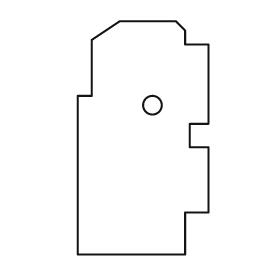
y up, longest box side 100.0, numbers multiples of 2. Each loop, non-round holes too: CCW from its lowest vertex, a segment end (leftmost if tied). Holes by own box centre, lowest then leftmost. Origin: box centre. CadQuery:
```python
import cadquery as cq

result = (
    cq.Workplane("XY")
    .moveTo(-28.0, -50.0)
    .lineTo(18.0, -50.0)
    .lineTo(18.0, -32.0)
    .lineTo(28.0, -32.0)
    .lineTo(28.0, -4.0)
    .lineTo(20.0, -4.0)
    .lineTo(20.0, 6.0)
    .lineTo(28.0, 6.0)
    .lineTo(28.0, 40.0)
    .lineTo(18.0, 40.0)
    .lineTo(18.0, 46.0)
    .lineTo(14.0, 50.0)
    .lineTo(-10.0, 50.0)
    .lineTo(-22.0, 42.0)
    .lineTo(-22.0, 18.0)
    .lineTo(-28.0, 18.0)
    .close()
    .moveTo(4.0, 14.0)
    .circle(4.0)
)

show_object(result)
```